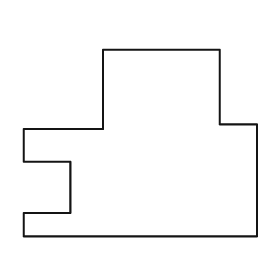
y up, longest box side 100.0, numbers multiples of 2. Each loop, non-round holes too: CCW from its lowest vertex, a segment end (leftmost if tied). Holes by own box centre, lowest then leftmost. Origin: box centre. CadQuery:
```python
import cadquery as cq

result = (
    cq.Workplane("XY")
    .moveTo(-50.0, -40.0)
    .lineTo(50.0, -40.0)
    .lineTo(50.0, 8.0)
    .lineTo(34.0, 8.0)
    .lineTo(34.0, 40.0)
    .lineTo(-16.0, 40.0)
    .lineTo(-16.0, 6.0)
    .lineTo(-50.0, 6.0)
    .lineTo(-50.0, -8.0)
    .lineTo(-30.0, -8.0)
    .lineTo(-30.0, -30.0)
    .lineTo(-50.0, -30.0)
    .close()
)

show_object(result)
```